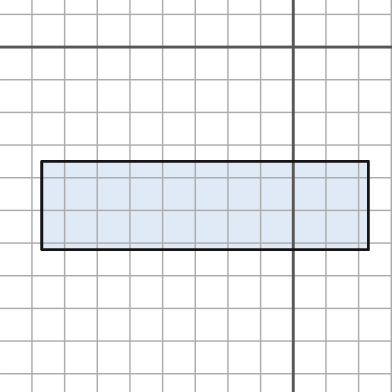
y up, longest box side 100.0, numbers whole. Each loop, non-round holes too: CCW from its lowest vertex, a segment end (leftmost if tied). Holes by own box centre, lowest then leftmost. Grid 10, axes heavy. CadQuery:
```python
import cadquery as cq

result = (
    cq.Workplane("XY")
    .moveTo(-77.0, -62.0)
    .lineTo(23.0, -62.0)
    .lineTo(23.0, -35.0)
    .lineTo(-77.0, -35.0)
    .close()
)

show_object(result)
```